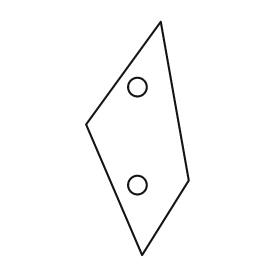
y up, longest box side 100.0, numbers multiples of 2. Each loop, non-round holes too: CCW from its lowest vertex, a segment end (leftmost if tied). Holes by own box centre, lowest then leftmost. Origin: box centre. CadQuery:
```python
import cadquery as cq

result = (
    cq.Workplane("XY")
    .moveTo(2.0, -50.0)
    .lineTo(22.0, -18.0)
    .lineTo(10.0, 50.0)
    .lineTo(-22.0, 6.0)
    .close()
    .moveTo(0.0, -20.0)
    .circle(4.0)
    .moveTo(0.0, 22.0)
    .circle(4.0)
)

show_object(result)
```